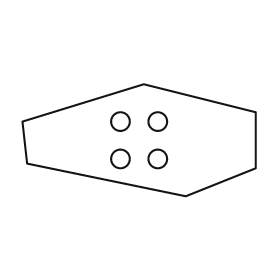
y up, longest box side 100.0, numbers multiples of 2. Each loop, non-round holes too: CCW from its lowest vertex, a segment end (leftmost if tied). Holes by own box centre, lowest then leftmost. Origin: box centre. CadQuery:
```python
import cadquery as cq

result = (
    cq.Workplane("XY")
    .moveTo(20.0, -24.0)
    .lineTo(50.0, -12.0)
    .lineTo(50.0, 12.0)
    .lineTo(2.0, 24.0)
    .lineTo(-50.0, 8.0)
    .lineTo(-48.0, -10.0)
    .close()
    .moveTo(-8.0, -8.0)
    .circle(4.0)
    .moveTo(8.0, -8.0)
    .circle(4.0)
    .moveTo(-8.0, 8.0)
    .circle(4.0)
    .moveTo(8.0, 8.0)
    .circle(4.0)
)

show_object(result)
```